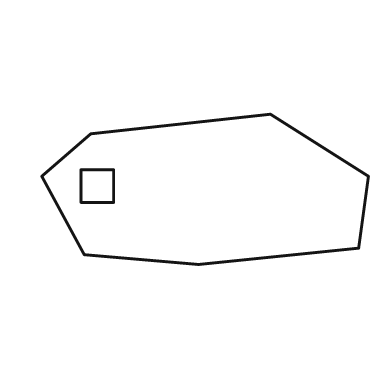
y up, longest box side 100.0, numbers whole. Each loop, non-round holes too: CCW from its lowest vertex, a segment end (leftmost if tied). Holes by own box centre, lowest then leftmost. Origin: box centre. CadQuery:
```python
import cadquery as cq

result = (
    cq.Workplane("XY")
    .moveTo(-2.0, -23.0)
    .lineTo(47.0, -18.0)
    .lineTo(50.0, 4.0)
    .lineTo(20.0, 23.0)
    .lineTo(-35.0, 17.0)
    .lineTo(-50.0, 4.0)
    .lineTo(-37.0, -20.0)
    .close()
    .moveTo(-38.0, -4.0)
    .lineTo(-28.0, -4.0)
    .lineTo(-28.0, 6.0)
    .lineTo(-38.0, 6.0)
    .close()
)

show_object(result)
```